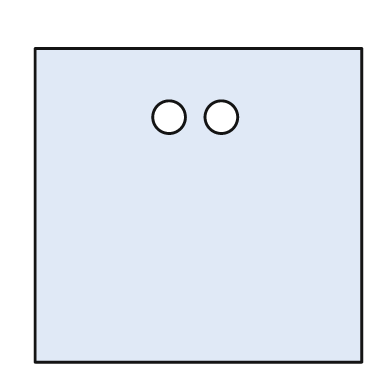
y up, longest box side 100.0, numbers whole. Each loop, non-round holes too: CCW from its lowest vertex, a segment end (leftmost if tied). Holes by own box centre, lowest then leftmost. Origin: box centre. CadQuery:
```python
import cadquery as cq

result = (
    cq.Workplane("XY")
    .moveTo(-50.0, -48.0)
    .lineTo(50.0, -48.0)
    .lineTo(50.0, 48.0)
    .lineTo(-50.0, 48.0)
    .close()
    .moveTo(-9.0, 27.0)
    .circle(5.0)
    .moveTo(7.0, 27.0)
    .circle(5.0)
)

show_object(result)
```